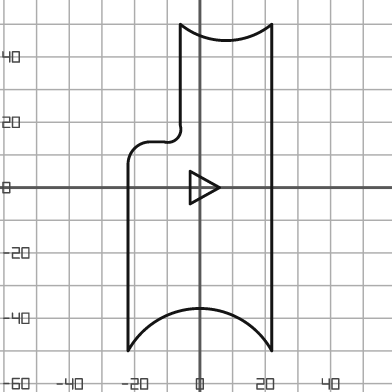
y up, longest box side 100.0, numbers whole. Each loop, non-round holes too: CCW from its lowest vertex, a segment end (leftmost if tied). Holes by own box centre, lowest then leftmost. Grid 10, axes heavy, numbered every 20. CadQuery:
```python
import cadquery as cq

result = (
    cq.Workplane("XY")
    .moveTo(-22.0, -50.0)
    .threePointArc((0.0, -37.0), (22.0, -50.0))
    .lineTo(22.0, 50.0)
    .threePointArc((8.0, 45.0), (-6.0, 50.0))
    .lineTo(-6.0, 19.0)
    .threePointArc((-7.0, 15.0), (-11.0, 14.0))
    .lineTo(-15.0, 14.0)
    .threePointArc((-20.0, 12.0), (-22.0, 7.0))
    .close()
    .moveTo(-3.0, -5.0)
    .lineTo(6.0, 0.0)
    .lineTo(-3.0, 5.0)
    .close()
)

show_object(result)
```